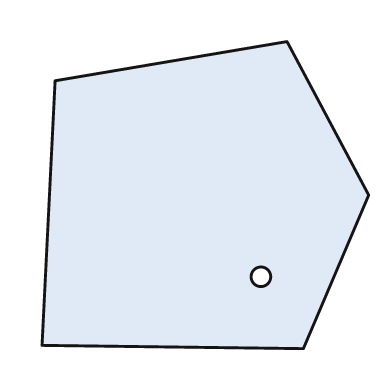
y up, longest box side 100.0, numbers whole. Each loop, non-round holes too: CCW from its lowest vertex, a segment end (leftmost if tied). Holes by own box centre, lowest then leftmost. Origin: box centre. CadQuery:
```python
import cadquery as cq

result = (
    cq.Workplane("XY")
    .moveTo(30.0, -47.0)
    .lineTo(50.0, 0.0)
    .lineTo(25.0, 47.0)
    .lineTo(-46.0, 35.0)
    .lineTo(-50.0, -46.0)
    .close()
    .moveTo(17.0, -25.0)
    .circle(3.0)
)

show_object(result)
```